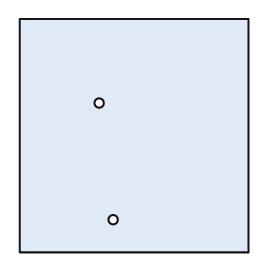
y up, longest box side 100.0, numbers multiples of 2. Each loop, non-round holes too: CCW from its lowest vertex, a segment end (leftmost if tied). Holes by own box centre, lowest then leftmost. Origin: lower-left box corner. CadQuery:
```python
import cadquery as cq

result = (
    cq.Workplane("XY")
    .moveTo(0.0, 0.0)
    .lineTo(98.0, 0.0)
    .lineTo(98.0, 100.0)
    .lineTo(0.0, 100.0)
    .close()
    .moveTo(40.0, 14.0)
    .circle(2.0)
    .moveTo(34.0, 64.0)
    .circle(2.0)
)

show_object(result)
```